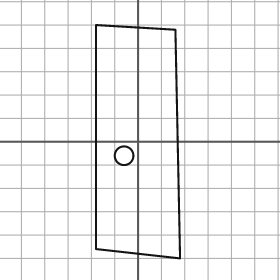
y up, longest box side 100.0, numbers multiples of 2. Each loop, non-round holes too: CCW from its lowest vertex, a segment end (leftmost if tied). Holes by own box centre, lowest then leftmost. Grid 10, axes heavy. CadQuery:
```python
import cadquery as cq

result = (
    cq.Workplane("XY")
    .moveTo(18.0, -50.0)
    .lineTo(16.0, 48.0)
    .lineTo(-18.0, 50.0)
    .lineTo(-18.0, -46.0)
    .close()
    .moveTo(-6.0, -6.0)
    .circle(4.0)
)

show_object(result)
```